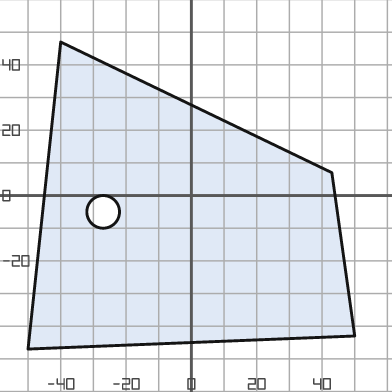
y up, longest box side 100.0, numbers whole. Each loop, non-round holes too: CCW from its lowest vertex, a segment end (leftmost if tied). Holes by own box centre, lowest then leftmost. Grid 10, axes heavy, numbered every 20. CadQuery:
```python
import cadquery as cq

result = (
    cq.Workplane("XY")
    .moveTo(-50.0, -47.0)
    .lineTo(50.0, -43.0)
    .lineTo(43.0, 7.0)
    .lineTo(-40.0, 47.0)
    .close()
    .moveTo(-27.0, -5.0)
    .circle(5.0)
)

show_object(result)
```